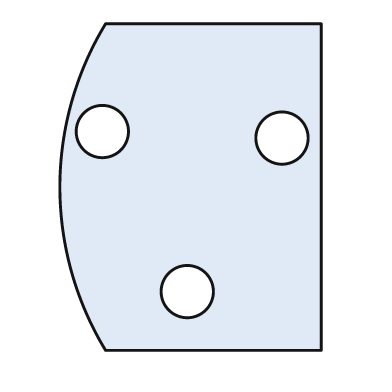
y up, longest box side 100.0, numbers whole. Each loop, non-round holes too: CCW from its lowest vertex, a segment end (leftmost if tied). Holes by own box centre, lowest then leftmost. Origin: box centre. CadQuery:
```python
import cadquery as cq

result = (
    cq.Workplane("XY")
    .moveTo(-26.0, -50.0)
    .lineTo(40.0, -50.0)
    .lineTo(40.0, 50.0)
    .lineTo(-26.0, 50.0)
    .threePointArc((-40.0, 0.0), (-26.0, -50.0))
    .close()
    .moveTo(-1.0, -32.0)
    .circle(8.0)
    .moveTo(28.0, 15.0)
    .circle(8.0)
    .moveTo(-27.0, 17.0)
    .circle(8.0)
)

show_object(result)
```